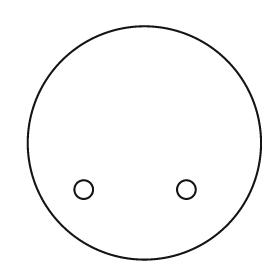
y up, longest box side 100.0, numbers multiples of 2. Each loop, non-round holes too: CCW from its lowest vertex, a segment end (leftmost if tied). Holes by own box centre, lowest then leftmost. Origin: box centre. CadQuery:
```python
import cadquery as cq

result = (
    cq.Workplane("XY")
    .moveTo(0.0, 0.0)
    .circle(50.0)
    .moveTo(-26.0, -20.0)
    .circle(4.0)
    .moveTo(18.0, -20.0)
    .circle(4.0)
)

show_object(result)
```